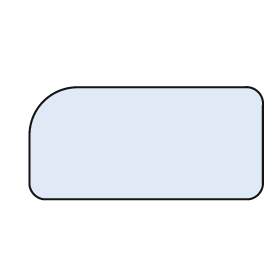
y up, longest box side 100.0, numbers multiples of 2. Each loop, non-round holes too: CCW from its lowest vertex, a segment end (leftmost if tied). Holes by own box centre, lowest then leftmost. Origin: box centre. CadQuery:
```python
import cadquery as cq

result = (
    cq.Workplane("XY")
    .moveTo(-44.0, -24.0)
    .lineTo(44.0, -24.0)
    .threePointArc((48.0, -22.0), (50.0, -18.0))
    .lineTo(50.0, 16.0)
    .threePointArc((48.0, 22.0), (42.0, 24.0))
    .lineTo(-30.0, 24.0)
    .threePointArc((-44.0, 18.0), (-50.0, 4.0))
    .lineTo(-50.0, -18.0)
    .threePointArc((-48.0, -22.0), (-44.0, -24.0))
    .close()
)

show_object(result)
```